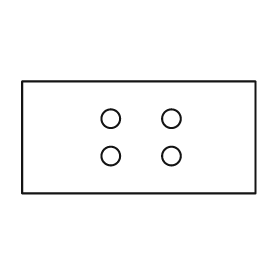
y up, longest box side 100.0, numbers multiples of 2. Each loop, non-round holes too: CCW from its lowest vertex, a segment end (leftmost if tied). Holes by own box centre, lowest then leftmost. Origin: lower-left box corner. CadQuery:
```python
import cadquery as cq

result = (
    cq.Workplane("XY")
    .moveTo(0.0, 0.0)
    .lineTo(100.0, 0.0)
    .lineTo(100.0, 48.0)
    .lineTo(0.0, 48.0)
    .close()
    .moveTo(38.0, 16.0)
    .circle(4.0)
    .moveTo(64.0, 16.0)
    .circle(4.0)
    .moveTo(38.0, 32.0)
    .circle(4.0)
    .moveTo(64.0, 32.0)
    .circle(4.0)
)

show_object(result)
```